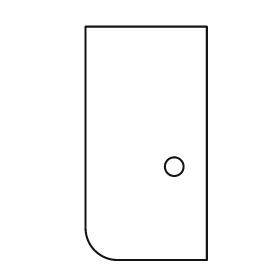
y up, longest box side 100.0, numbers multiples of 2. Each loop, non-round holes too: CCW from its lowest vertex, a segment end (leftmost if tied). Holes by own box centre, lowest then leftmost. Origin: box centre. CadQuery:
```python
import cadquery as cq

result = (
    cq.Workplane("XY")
    .moveTo(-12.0, -50.0)
    .lineTo(26.0, -50.0)
    .lineTo(26.0, 50.0)
    .lineTo(-26.0, 50.0)
    .lineTo(-26.0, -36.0)
    .threePointArc((-22.0, -46.0), (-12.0, -50.0))
    .close()
    .moveTo(12.0, -10.0)
    .circle(4.0)
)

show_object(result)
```